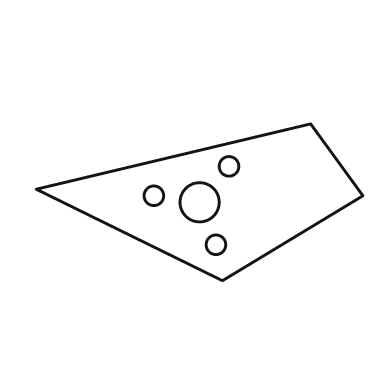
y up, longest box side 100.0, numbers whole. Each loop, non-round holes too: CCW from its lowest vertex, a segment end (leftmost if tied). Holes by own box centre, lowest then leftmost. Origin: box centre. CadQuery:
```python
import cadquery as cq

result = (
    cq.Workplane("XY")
    .moveTo(7.0, -24.0)
    .lineTo(50.0, 2.0)
    .lineTo(34.0, 24.0)
    .lineTo(-50.0, 4.0)
    .close()
    .moveTo(5.0, -13.0)
    .circle(3.0)
    .moveTo(0.0, 0.0)
    .circle(6.0)
    .moveTo(-14.0, 2.0)
    .circle(3.0)
    .moveTo(9.0, 11.0)
    .circle(3.0)
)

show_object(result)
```